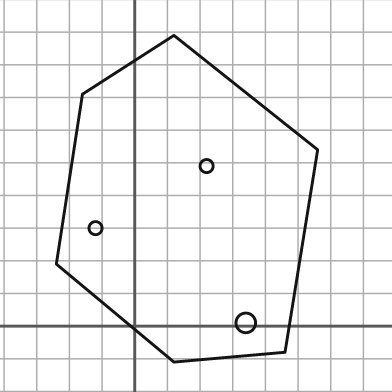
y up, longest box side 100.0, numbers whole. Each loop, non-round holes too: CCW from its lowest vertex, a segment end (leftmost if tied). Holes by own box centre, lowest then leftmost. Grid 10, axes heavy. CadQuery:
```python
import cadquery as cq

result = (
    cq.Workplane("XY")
    .moveTo(12.0, -11.0)
    .lineTo(46.0, -8.0)
    .lineTo(56.0, 54.0)
    .lineTo(12.0, 89.0)
    .lineTo(-16.0, 71.0)
    .lineTo(-24.0, 19.0)
    .close()
    .moveTo(34.0, 1.0)
    .circle(3.0)
    .moveTo(-12.0, 30.0)
    .circle(2.0)
    .moveTo(22.0, 49.0)
    .circle(2.0)
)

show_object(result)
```